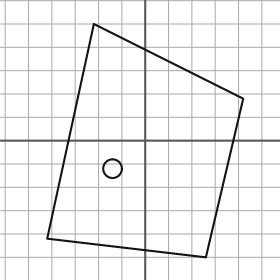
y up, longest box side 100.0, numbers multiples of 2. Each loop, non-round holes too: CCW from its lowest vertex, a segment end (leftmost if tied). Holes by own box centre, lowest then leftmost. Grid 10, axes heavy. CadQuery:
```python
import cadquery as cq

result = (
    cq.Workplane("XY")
    .moveTo(26.0, -50.0)
    .lineTo(42.0, 18.0)
    .lineTo(-22.0, 50.0)
    .lineTo(-42.0, -42.0)
    .close()
    .moveTo(-14.0, -12.0)
    .circle(4.0)
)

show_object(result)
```